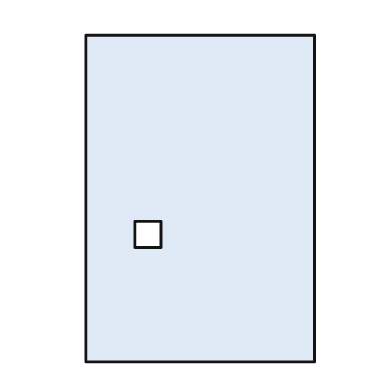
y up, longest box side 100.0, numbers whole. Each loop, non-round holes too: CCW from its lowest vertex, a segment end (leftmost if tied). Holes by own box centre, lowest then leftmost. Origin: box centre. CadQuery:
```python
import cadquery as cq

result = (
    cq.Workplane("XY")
    .moveTo(-35.0, -50.0)
    .lineTo(35.0, -50.0)
    .lineTo(35.0, 50.0)
    .lineTo(-35.0, 50.0)
    .close()
    .moveTo(-20.0, -15.0)
    .lineTo(-12.0, -15.0)
    .lineTo(-12.0, -7.0)
    .lineTo(-20.0, -7.0)
    .close()
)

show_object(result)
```